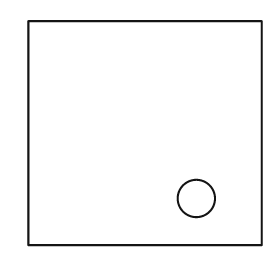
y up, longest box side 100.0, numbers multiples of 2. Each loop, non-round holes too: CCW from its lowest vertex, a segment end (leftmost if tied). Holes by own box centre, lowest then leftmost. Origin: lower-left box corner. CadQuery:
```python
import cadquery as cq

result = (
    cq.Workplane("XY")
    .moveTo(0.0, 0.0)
    .lineTo(100.0, 0.0)
    .lineTo(100.0, 96.0)
    .lineTo(0.0, 96.0)
    .close()
    .moveTo(72.0, 20.0)
    .circle(8.0)
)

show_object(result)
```